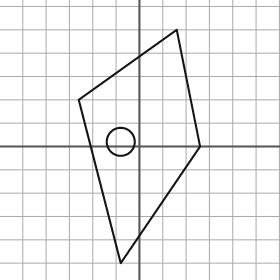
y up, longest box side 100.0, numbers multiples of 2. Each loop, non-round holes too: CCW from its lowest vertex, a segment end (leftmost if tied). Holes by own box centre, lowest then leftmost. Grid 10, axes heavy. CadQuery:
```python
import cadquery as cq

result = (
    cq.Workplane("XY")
    .moveTo(-8.0, -50.0)
    .lineTo(26.0, 0.0)
    .lineTo(16.0, 50.0)
    .lineTo(-26.0, 20.0)
    .close()
    .moveTo(-8.0, 2.0)
    .circle(6.0)
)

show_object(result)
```